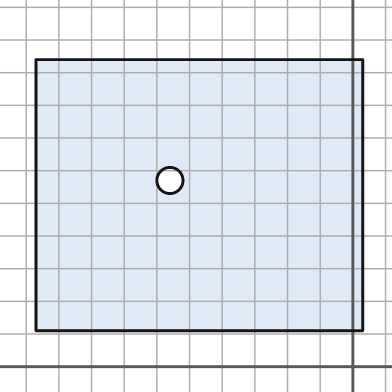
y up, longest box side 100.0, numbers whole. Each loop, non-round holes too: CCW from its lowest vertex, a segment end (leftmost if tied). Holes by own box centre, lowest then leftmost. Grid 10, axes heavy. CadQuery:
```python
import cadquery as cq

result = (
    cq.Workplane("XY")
    .moveTo(-97.0, 11.0)
    .lineTo(3.0, 11.0)
    .lineTo(3.0, 94.0)
    .lineTo(-97.0, 94.0)
    .close()
    .moveTo(-56.0, 57.0)
    .circle(4.0)
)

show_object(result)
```